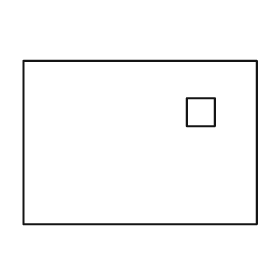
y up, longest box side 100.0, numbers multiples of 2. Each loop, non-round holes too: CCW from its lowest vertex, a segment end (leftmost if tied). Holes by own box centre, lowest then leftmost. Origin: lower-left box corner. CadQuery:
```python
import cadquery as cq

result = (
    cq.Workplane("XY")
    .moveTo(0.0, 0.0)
    .lineTo(100.0, 0.0)
    .lineTo(100.0, 70.0)
    .lineTo(0.0, 70.0)
    .close()
    .moveTo(70.0, 42.0)
    .lineTo(82.0, 42.0)
    .lineTo(82.0, 54.0)
    .lineTo(70.0, 54.0)
    .close()
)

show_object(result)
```